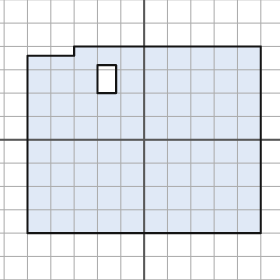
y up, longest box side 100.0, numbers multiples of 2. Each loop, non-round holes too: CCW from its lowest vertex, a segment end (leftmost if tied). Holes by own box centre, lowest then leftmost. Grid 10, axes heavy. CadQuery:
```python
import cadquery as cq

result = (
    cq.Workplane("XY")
    .moveTo(-50.0, -40.0)
    .lineTo(50.0, -40.0)
    .lineTo(50.0, 40.0)
    .lineTo(-30.0, 40.0)
    .lineTo(-30.0, 36.0)
    .lineTo(-50.0, 36.0)
    .close()
    .moveTo(-20.0, 20.0)
    .lineTo(-12.0, 20.0)
    .lineTo(-12.0, 32.0)
    .lineTo(-20.0, 32.0)
    .close()
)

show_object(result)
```